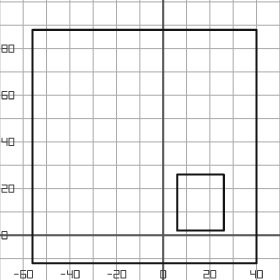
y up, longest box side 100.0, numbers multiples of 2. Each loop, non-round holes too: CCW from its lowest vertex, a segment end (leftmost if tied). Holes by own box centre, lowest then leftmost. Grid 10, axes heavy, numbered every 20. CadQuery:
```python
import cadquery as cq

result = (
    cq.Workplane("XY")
    .moveTo(-56.0, -12.0)
    .lineTo(40.0, -12.0)
    .lineTo(40.0, 88.0)
    .lineTo(-56.0, 88.0)
    .close()
    .moveTo(6.0, 2.0)
    .lineTo(26.0, 2.0)
    .lineTo(26.0, 26.0)
    .lineTo(6.0, 26.0)
    .close()
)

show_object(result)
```